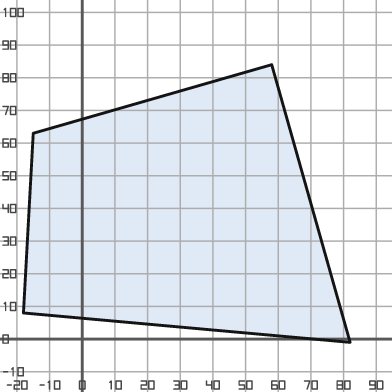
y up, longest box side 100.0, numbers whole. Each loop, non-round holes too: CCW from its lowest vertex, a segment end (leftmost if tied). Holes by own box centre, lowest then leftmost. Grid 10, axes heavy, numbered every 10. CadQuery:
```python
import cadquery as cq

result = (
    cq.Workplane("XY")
    .moveTo(82.0, -1.0)
    .lineTo(58.0, 84.0)
    .lineTo(-15.0, 63.0)
    .lineTo(-18.0, 8.0)
    .close()
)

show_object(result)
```